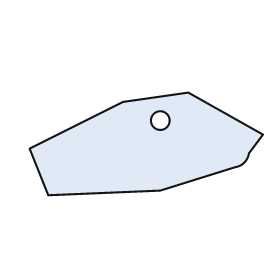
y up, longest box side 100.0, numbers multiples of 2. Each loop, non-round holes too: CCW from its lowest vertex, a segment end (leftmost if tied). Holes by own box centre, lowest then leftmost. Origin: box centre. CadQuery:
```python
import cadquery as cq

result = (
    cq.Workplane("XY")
    .moveTo(-42.0, -22.0)
    .lineTo(6.0, -20.0)
    .lineTo(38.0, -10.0)
    .threePointArc((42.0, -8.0), (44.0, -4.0))
    .lineTo(50.0, 4.0)
    .lineTo(18.0, 22.0)
    .lineTo(-10.0, 18.0)
    .lineTo(-50.0, -2.0)
    .close()
    .moveTo(6.0, 10.0)
    .circle(4.0)
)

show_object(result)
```